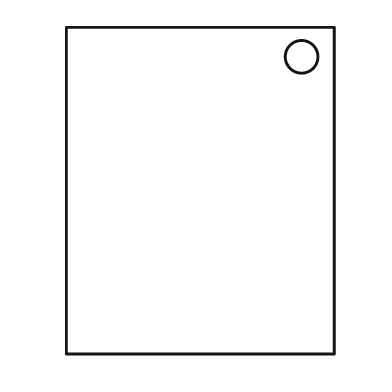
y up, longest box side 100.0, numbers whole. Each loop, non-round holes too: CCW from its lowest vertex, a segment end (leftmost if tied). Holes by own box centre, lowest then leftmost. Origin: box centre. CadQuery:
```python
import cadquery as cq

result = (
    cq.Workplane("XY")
    .moveTo(-41.0, -50.0)
    .lineTo(41.0, -50.0)
    .lineTo(41.0, 50.0)
    .lineTo(-41.0, 50.0)
    .close()
    .moveTo(31.0, 41.0)
    .circle(5.0)
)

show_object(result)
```